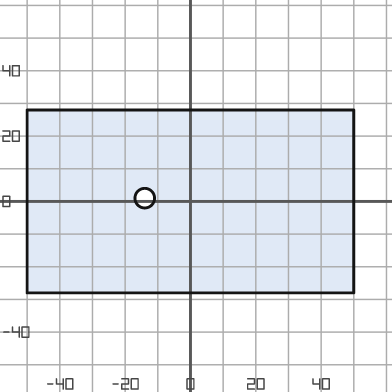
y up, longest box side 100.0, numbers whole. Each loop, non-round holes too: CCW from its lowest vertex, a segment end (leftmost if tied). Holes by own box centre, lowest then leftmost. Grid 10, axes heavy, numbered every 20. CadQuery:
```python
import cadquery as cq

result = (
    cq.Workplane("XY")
    .moveTo(-50.0, -28.0)
    .lineTo(50.0, -28.0)
    .lineTo(50.0, 28.0)
    .lineTo(-50.0, 28.0)
    .close()
    .moveTo(-14.0, 1.0)
    .circle(3.0)
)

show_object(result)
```